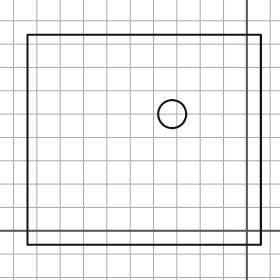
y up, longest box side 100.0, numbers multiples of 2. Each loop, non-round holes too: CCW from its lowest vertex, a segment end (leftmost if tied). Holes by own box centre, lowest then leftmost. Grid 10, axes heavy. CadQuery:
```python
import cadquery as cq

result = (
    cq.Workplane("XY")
    .moveTo(-94.0, -6.0)
    .lineTo(6.0, -6.0)
    .lineTo(6.0, 84.0)
    .lineTo(-94.0, 84.0)
    .close()
    .moveTo(-32.0, 50.0)
    .circle(6.0)
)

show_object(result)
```